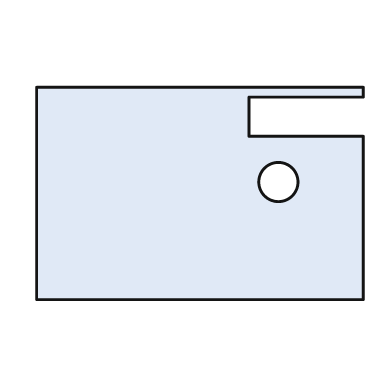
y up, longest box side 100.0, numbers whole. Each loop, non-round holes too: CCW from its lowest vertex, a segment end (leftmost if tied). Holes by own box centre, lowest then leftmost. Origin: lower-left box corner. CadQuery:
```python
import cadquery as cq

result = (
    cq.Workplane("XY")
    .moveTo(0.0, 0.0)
    .lineTo(100.0, 0.0)
    .lineTo(100.0, 50.0)
    .lineTo(65.0, 50.0)
    .lineTo(65.0, 62.0)
    .lineTo(100.0, 62.0)
    .lineTo(100.0, 65.0)
    .lineTo(0.0, 65.0)
    .close()
    .moveTo(74.0, 36.0)
    .circle(6.0)
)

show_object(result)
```